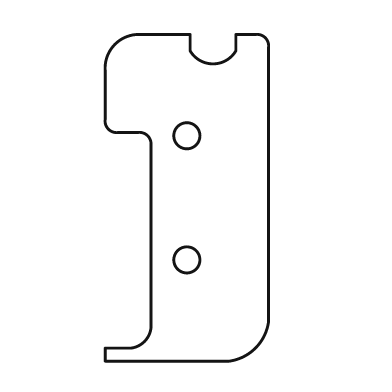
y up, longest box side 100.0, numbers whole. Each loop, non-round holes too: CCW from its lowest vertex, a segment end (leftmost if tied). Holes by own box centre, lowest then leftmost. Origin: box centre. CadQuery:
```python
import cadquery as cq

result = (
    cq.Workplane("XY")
    .moveTo(-25.0, -50.0)
    .lineTo(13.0, -50.0)
    .threePointArc((21.0, -46.0), (25.0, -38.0))
    .lineTo(25.0, 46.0)
    .threePointArc((24.0, 49.0), (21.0, 50.0))
    .lineTo(15.0, 50.0)
    .lineTo(15.0, 45.0)
    .threePointArc((8.0, 41.0), (1.0, 45.0))
    .lineTo(1.0, 50.0)
    .lineTo(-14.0, 50.0)
    .threePointArc((-22.0, 47.0), (-25.0, 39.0))
    .lineTo(-25.0, 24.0)
    .threePointArc((-24.0, 21.0), (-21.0, 20.0))
    .lineTo(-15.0, 20.0)
    .threePointArc((-12.0, 19.0), (-11.0, 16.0))
    .lineTo(-11.0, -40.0)
    .threePointArc((-13.0, -44.0), (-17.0, -46.0))
    .lineTo(-25.0, -46.0)
    .close()
    .moveTo(0.0, -19.0)
    .circle(4.0)
    .moveTo(0.0, 19.0)
    .circle(4.0)
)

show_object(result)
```